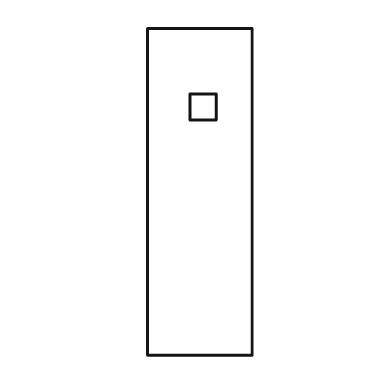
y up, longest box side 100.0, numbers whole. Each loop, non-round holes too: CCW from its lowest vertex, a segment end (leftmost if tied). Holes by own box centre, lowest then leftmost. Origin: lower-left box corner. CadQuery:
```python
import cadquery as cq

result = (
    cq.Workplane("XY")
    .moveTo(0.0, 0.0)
    .lineTo(32.0, 0.0)
    .lineTo(32.0, 100.0)
    .lineTo(0.0, 100.0)
    .close()
    .moveTo(13.0, 72.0)
    .lineTo(21.0, 72.0)
    .lineTo(21.0, 80.0)
    .lineTo(13.0, 80.0)
    .close()
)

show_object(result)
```